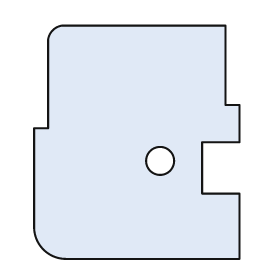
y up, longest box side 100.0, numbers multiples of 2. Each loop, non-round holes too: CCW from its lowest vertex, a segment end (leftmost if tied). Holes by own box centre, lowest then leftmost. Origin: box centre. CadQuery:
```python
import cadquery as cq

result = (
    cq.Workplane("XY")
    .moveTo(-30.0, -50.0)
    .lineTo(44.0, -50.0)
    .lineTo(44.0, -22.0)
    .lineTo(28.0, -22.0)
    .lineTo(28.0, 0.0)
    .lineTo(44.0, 0.0)
    .lineTo(44.0, 16.0)
    .lineTo(38.0, 16.0)
    .lineTo(38.0, 50.0)
    .lineTo(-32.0, 50.0)
    .threePointArc((-36.0, 48.0), (-38.0, 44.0))
    .lineTo(-38.0, 6.0)
    .lineTo(-44.0, 6.0)
    .lineTo(-44.0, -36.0)
    .threePointArc((-40.0, -46.0), (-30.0, -50.0))
    .close()
    .moveTo(10.0, -8.0)
    .circle(6.0)
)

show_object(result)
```